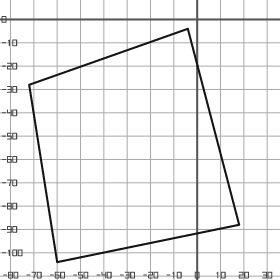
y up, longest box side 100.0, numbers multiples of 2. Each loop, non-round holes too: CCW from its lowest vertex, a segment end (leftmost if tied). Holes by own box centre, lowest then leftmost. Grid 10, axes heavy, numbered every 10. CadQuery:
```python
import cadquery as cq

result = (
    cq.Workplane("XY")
    .moveTo(-60.0, -104.0)
    .lineTo(18.0, -88.0)
    .lineTo(-4.0, -4.0)
    .lineTo(-72.0, -28.0)
    .close()
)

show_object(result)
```